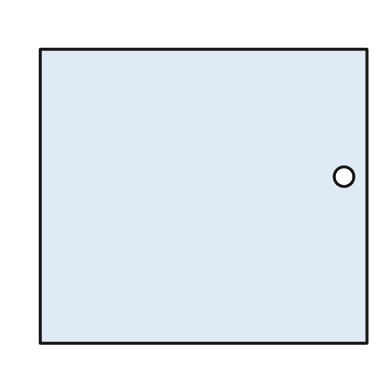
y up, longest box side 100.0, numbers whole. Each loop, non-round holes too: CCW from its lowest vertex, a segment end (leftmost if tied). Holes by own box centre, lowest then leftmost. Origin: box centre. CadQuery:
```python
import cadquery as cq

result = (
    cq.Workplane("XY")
    .moveTo(-50.0, -45.0)
    .lineTo(50.0, -45.0)
    .lineTo(50.0, 45.0)
    .lineTo(-50.0, 45.0)
    .close()
    .moveTo(43.0, 6.0)
    .circle(3.0)
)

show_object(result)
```